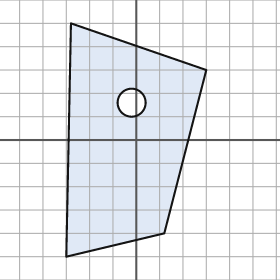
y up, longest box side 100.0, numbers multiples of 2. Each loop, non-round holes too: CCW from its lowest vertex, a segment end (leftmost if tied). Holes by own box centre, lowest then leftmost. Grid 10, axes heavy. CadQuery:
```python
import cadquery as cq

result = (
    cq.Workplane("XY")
    .moveTo(-30.0, -50.0)
    .lineTo(12.0, -40.0)
    .lineTo(30.0, 30.0)
    .lineTo(-28.0, 50.0)
    .close()
    .moveTo(-2.0, 16.0)
    .circle(6.0)
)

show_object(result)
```